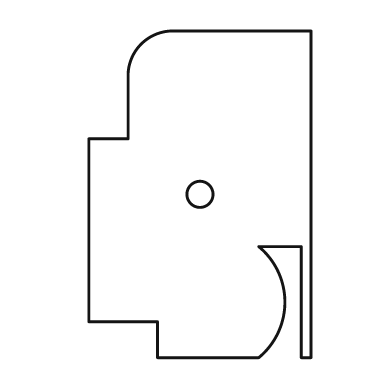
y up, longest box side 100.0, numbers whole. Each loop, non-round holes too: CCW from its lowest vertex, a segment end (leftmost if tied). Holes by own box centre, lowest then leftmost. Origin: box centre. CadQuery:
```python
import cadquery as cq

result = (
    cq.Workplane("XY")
    .moveTo(-13.0, -50.0)
    .lineTo(18.0, -50.0)
    .threePointArc((26.0, -33.0), (18.0, -16.0))
    .lineTo(31.0, -16.0)
    .lineTo(31.0, -50.0)
    .lineTo(34.0, -50.0)
    .lineTo(34.0, 50.0)
    .lineTo(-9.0, 50.0)
    .threePointArc((-18.0, 46.0), (-22.0, 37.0))
    .lineTo(-22.0, 17.0)
    .lineTo(-34.0, 17.0)
    .lineTo(-34.0, -39.0)
    .lineTo(-13.0, -39.0)
    .close()
    .moveTo(0.0, 0.0)
    .circle(4.0)
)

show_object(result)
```